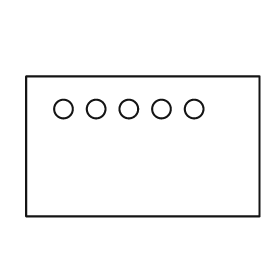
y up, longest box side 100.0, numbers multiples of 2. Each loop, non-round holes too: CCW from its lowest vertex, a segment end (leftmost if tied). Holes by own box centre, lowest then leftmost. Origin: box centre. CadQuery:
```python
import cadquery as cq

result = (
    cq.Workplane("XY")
    .moveTo(-50.0, -30.0)
    .lineTo(50.0, -30.0)
    .lineTo(50.0, 30.0)
    .lineTo(-50.0, 30.0)
    .close()
    .moveTo(-34.0, 16.0)
    .circle(4.0)
    .moveTo(-20.0, 16.0)
    .circle(4.0)
    .moveTo(-6.0, 16.0)
    .circle(4.0)
    .moveTo(8.0, 16.0)
    .circle(4.0)
    .moveTo(22.0, 16.0)
    .circle(4.0)
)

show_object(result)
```